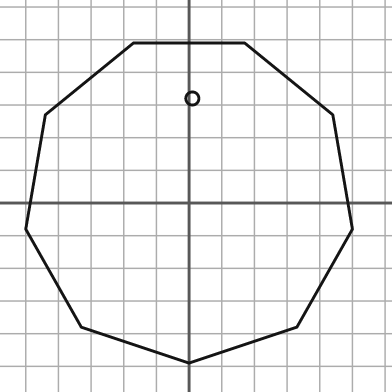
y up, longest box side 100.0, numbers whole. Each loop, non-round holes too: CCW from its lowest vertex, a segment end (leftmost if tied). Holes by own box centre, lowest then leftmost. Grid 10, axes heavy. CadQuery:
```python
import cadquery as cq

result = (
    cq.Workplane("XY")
    .moveTo(0.0, -49.0)
    .lineTo(33.0, -38.0)
    .lineTo(50.0, -8.0)
    .lineTo(44.0, 27.0)
    .lineTo(17.0, 49.0)
    .lineTo(-17.0, 49.0)
    .lineTo(-44.0, 27.0)
    .lineTo(-50.0, -8.0)
    .lineTo(-33.0, -38.0)
    .close()
    .moveTo(1.0, 32.0)
    .circle(2.0)
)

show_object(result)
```